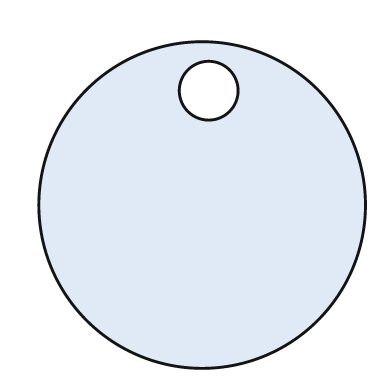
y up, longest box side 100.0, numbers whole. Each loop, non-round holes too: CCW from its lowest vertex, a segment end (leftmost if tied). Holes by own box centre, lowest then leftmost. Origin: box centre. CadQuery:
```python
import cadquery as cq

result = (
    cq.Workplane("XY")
    .moveTo(0.0, 0.0)
    .circle(50.0)
    .moveTo(2.0, 35.0)
    .circle(9.0)
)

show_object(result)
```